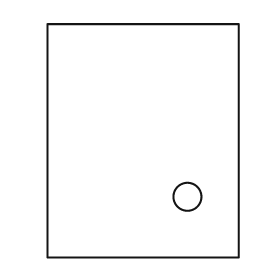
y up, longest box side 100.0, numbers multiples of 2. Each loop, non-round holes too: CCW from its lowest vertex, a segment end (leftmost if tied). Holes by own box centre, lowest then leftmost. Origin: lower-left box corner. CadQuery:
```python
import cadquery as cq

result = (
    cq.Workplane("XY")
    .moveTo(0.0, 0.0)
    .lineTo(82.0, 0.0)
    .lineTo(82.0, 100.0)
    .lineTo(0.0, 100.0)
    .close()
    .moveTo(60.0, 26.0)
    .circle(6.0)
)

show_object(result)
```